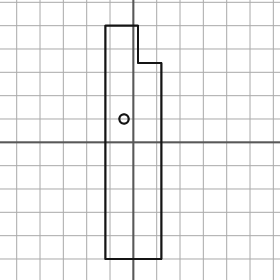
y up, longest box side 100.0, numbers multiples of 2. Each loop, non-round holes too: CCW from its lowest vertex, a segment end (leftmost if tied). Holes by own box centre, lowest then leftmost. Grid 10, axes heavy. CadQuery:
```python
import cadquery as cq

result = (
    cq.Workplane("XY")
    .moveTo(-12.0, -50.0)
    .lineTo(12.0, -50.0)
    .lineTo(12.0, 34.0)
    .lineTo(2.0, 34.0)
    .lineTo(2.0, 50.0)
    .lineTo(-12.0, 50.0)
    .close()
    .moveTo(-4.0, 10.0)
    .circle(2.0)
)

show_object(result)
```